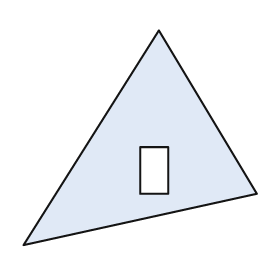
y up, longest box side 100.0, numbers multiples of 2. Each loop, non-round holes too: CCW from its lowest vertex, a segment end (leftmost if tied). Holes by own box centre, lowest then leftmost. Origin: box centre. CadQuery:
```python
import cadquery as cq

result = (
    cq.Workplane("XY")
    .moveTo(-50.0, -46.0)
    .lineTo(50.0, -24.0)
    .lineTo(8.0, 46.0)
    .close()
    .moveTo(0.0, -24.0)
    .lineTo(12.0, -24.0)
    .lineTo(12.0, -4.0)
    .lineTo(0.0, -4.0)
    .close()
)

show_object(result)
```